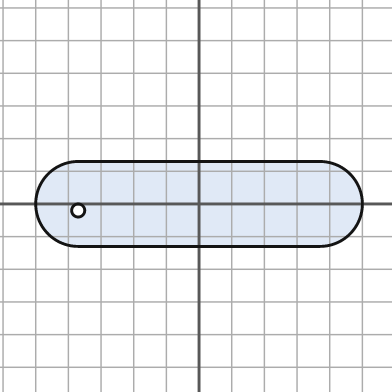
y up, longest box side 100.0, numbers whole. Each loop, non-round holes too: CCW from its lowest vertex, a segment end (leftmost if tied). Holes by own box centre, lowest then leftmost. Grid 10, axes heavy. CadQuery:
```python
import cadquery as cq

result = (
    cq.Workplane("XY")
    .moveTo(-37.0, -13.0)
    .lineTo(37.0, -13.0)
    .threePointArc((50.0, 0.0), (37.0, 13.0))
    .lineTo(-37.0, 13.0)
    .threePointArc((-50.0, 0.0), (-37.0, -13.0))
    .close()
    .moveTo(-37.0, -2.0)
    .circle(2.0)
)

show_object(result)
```